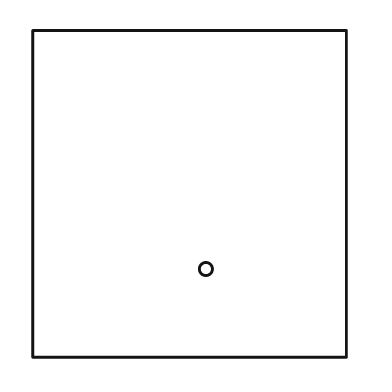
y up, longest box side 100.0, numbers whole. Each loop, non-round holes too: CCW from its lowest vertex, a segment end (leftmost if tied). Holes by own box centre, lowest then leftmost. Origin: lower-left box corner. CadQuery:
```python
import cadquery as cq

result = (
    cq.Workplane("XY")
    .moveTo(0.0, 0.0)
    .lineTo(96.0, 0.0)
    .lineTo(96.0, 100.0)
    .lineTo(0.0, 100.0)
    .close()
    .moveTo(53.0, 27.0)
    .circle(2.0)
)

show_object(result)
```